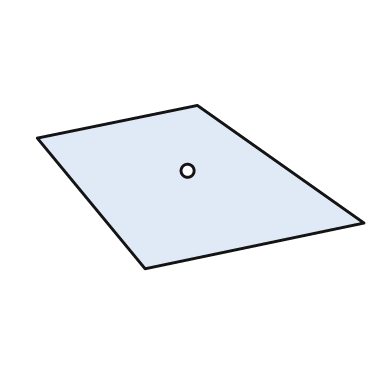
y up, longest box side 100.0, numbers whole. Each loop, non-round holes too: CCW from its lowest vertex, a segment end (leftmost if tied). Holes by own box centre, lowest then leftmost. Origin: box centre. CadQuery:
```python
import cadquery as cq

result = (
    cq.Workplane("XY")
    .moveTo(-17.0, -25.0)
    .lineTo(50.0, -11.0)
    .lineTo(-1.0, 25.0)
    .lineTo(-50.0, 15.0)
    .close()
    .moveTo(-4.0, 5.0)
    .circle(2.0)
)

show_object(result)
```